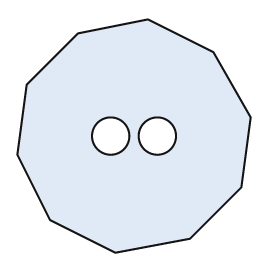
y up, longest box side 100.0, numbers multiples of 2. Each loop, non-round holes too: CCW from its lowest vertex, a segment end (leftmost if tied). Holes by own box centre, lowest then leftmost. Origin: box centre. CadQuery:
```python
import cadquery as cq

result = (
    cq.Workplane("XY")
    .moveTo(-8.0, -50.0)
    .lineTo(24.0, -44.0)
    .lineTo(46.0, -22.0)
    .lineTo(50.0, 8.0)
    .lineTo(34.0, 36.0)
    .lineTo(6.0, 50.0)
    .lineTo(-24.0, 44.0)
    .lineTo(-46.0, 22.0)
    .lineTo(-50.0, -8.0)
    .lineTo(-36.0, -36.0)
    .close()
    .moveTo(-10.0, 0.0)
    .circle(8.0)
    .moveTo(10.0, 0.0)
    .circle(8.0)
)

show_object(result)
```